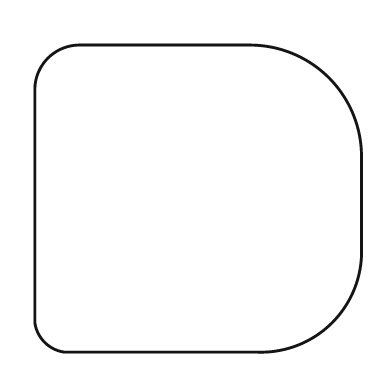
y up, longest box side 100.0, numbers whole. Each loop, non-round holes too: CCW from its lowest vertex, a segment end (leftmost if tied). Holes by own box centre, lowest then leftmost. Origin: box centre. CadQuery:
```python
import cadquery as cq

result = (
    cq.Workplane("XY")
    .moveTo(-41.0, -47.0)
    .lineTo(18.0, -47.0)
    .threePointArc((41.0, -38.0), (50.0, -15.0))
    .lineTo(50.0, 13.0)
    .threePointArc((40.0, 37.0), (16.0, 47.0))
    .lineTo(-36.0, 47.0)
    .threePointArc((-46.0, 43.0), (-50.0, 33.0))
    .lineTo(-50.0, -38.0)
    .threePointArc((-47.0, -44.0), (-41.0, -47.0))
    .close()
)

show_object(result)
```